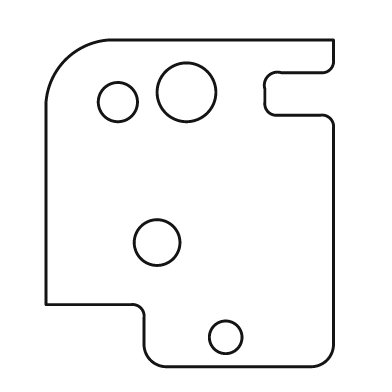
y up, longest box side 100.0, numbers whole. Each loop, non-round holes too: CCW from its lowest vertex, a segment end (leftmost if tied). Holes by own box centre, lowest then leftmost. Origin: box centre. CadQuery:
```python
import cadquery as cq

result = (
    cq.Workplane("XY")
    .moveTo(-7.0, -50.0)
    .lineTo(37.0, -50.0)
    .threePointArc((42.0, -48.0), (44.0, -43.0))
    .lineTo(44.0, 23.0)
    .threePointArc((43.0, 26.0), (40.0, 27.0))
    .lineTo(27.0, 27.0)
    .threePointArc((24.0, 28.0), (23.0, 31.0))
    .lineTo(23.0, 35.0)
    .threePointArc((24.0, 39.0), (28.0, 40.0))
    .lineTo(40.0, 40.0)
    .threePointArc((43.0, 41.0), (44.0, 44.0))
    .lineTo(44.0, 50.0)
    .lineTo(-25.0, 50.0)
    .threePointArc((-38.0, 44.0), (-44.0, 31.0))
    .lineTo(-44.0, -31.0)
    .lineTo(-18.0, -31.0)
    .threePointArc((-15.0, -32.0), (-14.0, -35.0))
    .lineTo(-14.0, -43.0)
    .threePointArc((-12.0, -48.0), (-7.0, -50.0))
    .close()
    .moveTo(11.0, -41.0)
    .circle(5.0)
    .moveTo(-10.0, -12.0)
    .circle(7.0)
    .moveTo(-22.0, 31.0)
    .circle(6.0)
    .moveTo(-1.0, 34.0)
    .circle(9.0)
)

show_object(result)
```